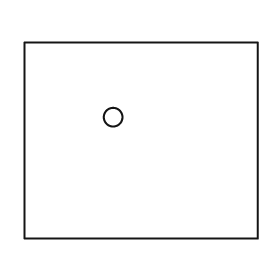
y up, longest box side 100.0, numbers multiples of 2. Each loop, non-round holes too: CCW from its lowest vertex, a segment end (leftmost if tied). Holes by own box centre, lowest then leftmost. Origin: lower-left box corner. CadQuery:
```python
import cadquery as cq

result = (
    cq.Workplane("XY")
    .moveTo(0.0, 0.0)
    .lineTo(100.0, 0.0)
    .lineTo(100.0, 84.0)
    .lineTo(0.0, 84.0)
    .close()
    .moveTo(38.0, 52.0)
    .circle(4.0)
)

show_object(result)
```